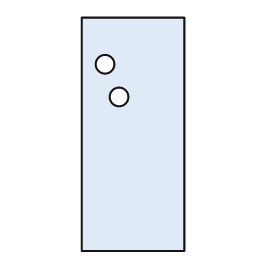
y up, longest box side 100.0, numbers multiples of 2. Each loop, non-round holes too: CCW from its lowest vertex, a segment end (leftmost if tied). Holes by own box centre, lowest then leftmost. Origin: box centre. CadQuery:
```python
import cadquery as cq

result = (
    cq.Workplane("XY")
    .moveTo(-22.0, -50.0)
    .lineTo(22.0, -50.0)
    .lineTo(22.0, 50.0)
    .lineTo(-22.0, 50.0)
    .close()
    .moveTo(-6.0, 16.0)
    .circle(4.0)
    .moveTo(-12.0, 30.0)
    .circle(4.0)
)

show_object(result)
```